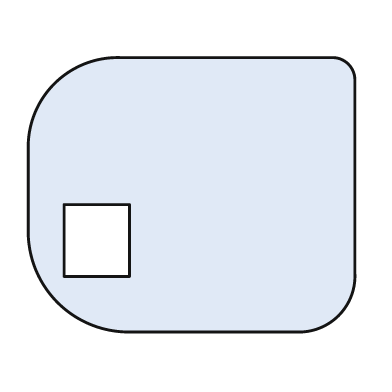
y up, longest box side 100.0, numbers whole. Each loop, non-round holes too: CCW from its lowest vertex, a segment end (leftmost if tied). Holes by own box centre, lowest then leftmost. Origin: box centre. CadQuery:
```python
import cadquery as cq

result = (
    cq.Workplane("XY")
    .moveTo(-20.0, -42.0)
    .lineTo(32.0, -42.0)
    .threePointArc((45.0, -37.0), (50.0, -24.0))
    .lineTo(50.0, 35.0)
    .threePointArc((48.0, 40.0), (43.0, 42.0))
    .lineTo(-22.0, 42.0)
    .threePointArc((-42.0, 34.0), (-50.0, 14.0))
    .lineTo(-50.0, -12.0)
    .threePointArc((-41.0, -33.0), (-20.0, -42.0))
    .close()
    .moveTo(-39.0, -25.0)
    .lineTo(-19.0, -25.0)
    .lineTo(-19.0, -3.0)
    .lineTo(-39.0, -3.0)
    .close()
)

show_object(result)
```